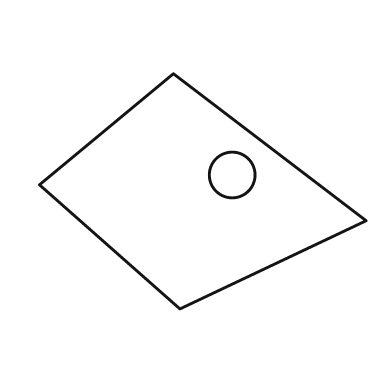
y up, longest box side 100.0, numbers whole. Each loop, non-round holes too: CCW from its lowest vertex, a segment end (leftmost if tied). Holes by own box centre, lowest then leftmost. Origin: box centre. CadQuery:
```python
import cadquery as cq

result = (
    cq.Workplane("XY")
    .moveTo(-7.0, -36.0)
    .lineTo(50.0, -9.0)
    .lineTo(-9.0, 36.0)
    .lineTo(-50.0, 2.0)
    .close()
    .moveTo(9.0, 5.0)
    .circle(7.0)
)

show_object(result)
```